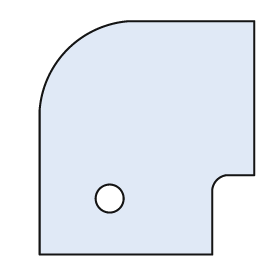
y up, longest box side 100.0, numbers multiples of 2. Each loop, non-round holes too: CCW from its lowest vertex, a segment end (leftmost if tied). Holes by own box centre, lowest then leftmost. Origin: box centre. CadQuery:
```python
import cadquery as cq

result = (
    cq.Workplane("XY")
    .moveTo(-46.0, -50.0)
    .lineTo(28.0, -50.0)
    .lineTo(28.0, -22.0)
    .threePointArc((30.0, -18.0), (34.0, -16.0))
    .lineTo(46.0, -16.0)
    .lineTo(46.0, 50.0)
    .lineTo(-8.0, 50.0)
    .threePointArc((-34.0, 38.0), (-46.0, 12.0))
    .close()
    .moveTo(-16.0, -26.0)
    .circle(6.0)
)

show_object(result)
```